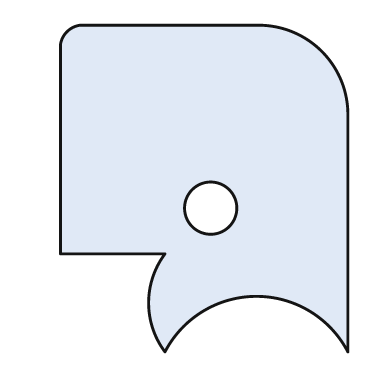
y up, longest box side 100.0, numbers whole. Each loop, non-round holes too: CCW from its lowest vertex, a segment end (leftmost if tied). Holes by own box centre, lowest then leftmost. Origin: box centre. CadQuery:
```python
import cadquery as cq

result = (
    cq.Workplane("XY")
    .moveTo(-12.0, -50.0)
    .threePointArc((16.0, -33.0), (44.0, -50.0))
    .lineTo(44.0, 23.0)
    .threePointArc((36.0, 42.0), (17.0, 50.0))
    .lineTo(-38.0, 50.0)
    .threePointArc((-42.0, 48.0), (-44.0, 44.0))
    .lineTo(-44.0, -20.0)
    .lineTo(-12.0, -20.0)
    .threePointArc((-17.0, -35.0), (-12.0, -50.0))
    .close()
    .moveTo(2.0, -6.0)
    .circle(8.0)
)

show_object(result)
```